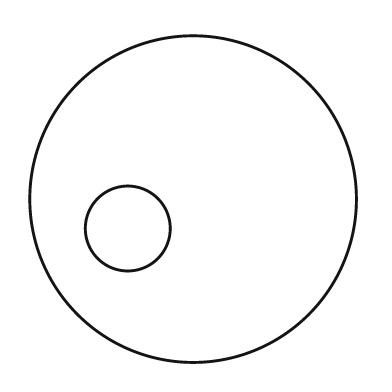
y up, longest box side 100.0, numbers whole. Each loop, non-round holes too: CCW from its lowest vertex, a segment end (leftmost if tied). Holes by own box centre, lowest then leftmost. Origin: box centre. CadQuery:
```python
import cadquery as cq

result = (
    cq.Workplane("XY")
    .moveTo(0.0, 0.0)
    .circle(50.0)
    .moveTo(-20.0, -9.0)
    .circle(13.0)
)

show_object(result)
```